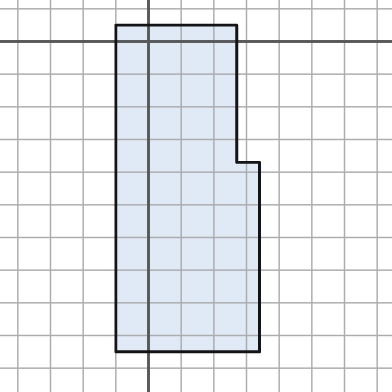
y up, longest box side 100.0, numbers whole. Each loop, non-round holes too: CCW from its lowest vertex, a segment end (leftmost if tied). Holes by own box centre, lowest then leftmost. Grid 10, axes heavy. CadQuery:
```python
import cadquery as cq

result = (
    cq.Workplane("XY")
    .moveTo(-10.0, -95.0)
    .lineTo(34.0, -95.0)
    .lineTo(34.0, -37.0)
    .lineTo(27.0, -37.0)
    .lineTo(27.0, 5.0)
    .lineTo(-10.0, 5.0)
    .close()
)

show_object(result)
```